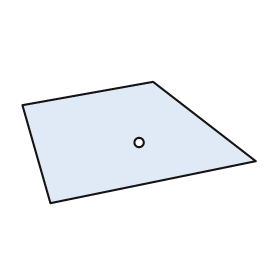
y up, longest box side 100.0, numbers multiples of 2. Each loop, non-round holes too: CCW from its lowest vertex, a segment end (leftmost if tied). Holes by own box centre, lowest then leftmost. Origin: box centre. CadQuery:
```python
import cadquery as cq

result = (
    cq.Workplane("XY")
    .moveTo(-38.0, -26.0)
    .lineTo(50.0, -8.0)
    .lineTo(6.0, 26.0)
    .lineTo(-50.0, 16.0)
    .close()
    .moveTo(0.0, 0.0)
    .circle(2.0)
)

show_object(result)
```